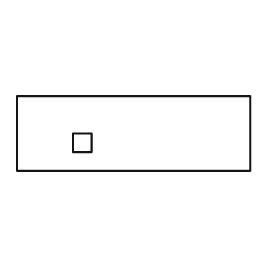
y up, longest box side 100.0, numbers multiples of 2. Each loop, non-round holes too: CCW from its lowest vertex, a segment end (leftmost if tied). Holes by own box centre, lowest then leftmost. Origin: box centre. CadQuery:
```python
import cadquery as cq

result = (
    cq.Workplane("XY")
    .moveTo(-50.0, -16.0)
    .lineTo(50.0, -16.0)
    .lineTo(50.0, 16.0)
    .lineTo(-50.0, 16.0)
    .close()
    .moveTo(-26.0, -8.0)
    .lineTo(-18.0, -8.0)
    .lineTo(-18.0, 0.0)
    .lineTo(-26.0, 0.0)
    .close()
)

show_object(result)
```